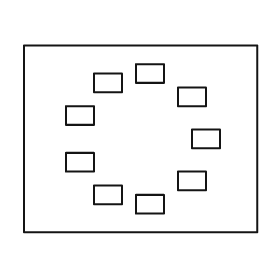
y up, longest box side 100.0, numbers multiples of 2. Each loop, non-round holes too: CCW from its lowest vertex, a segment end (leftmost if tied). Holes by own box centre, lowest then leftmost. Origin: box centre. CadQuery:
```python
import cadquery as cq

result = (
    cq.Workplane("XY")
    .moveTo(-50.0, -40.0)
    .lineTo(50.0, -40.0)
    .lineTo(50.0, 40.0)
    .lineTo(-50.0, 40.0)
    .close()
    .moveTo(-2.0, -32.0)
    .lineTo(10.0, -32.0)
    .lineTo(10.0, -24.0)
    .lineTo(-2.0, -24.0)
    .close()
    .moveTo(-20.0, -28.0)
    .lineTo(-8.0, -28.0)
    .lineTo(-8.0, -20.0)
    .lineTo(-20.0, -20.0)
    .close()
    .moveTo(16.0, -22.0)
    .lineTo(28.0, -22.0)
    .lineTo(28.0, -14.0)
    .lineTo(16.0, -14.0)
    .close()
    .moveTo(-32.0, -14.0)
    .lineTo(-20.0, -14.0)
    .lineTo(-20.0, -6.0)
    .lineTo(-32.0, -6.0)
    .close()
    .moveTo(22.0, -4.0)
    .lineTo(34.0, -4.0)
    .lineTo(34.0, 4.0)
    .lineTo(22.0, 4.0)
    .close()
    .moveTo(-32.0, 6.0)
    .lineTo(-20.0, 6.0)
    .lineTo(-20.0, 14.0)
    .lineTo(-32.0, 14.0)
    .close()
    .moveTo(16.0, 14.0)
    .lineTo(28.0, 14.0)
    .lineTo(28.0, 22.0)
    .lineTo(16.0, 22.0)
    .close()
    .moveTo(-20.0, 20.0)
    .lineTo(-8.0, 20.0)
    .lineTo(-8.0, 28.0)
    .lineTo(-20.0, 28.0)
    .close()
    .moveTo(-2.0, 24.0)
    .lineTo(10.0, 24.0)
    .lineTo(10.0, 32.0)
    .lineTo(-2.0, 32.0)
    .close()
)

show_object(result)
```